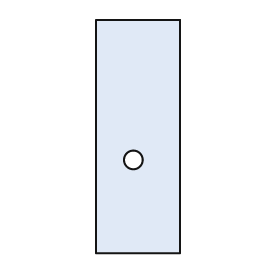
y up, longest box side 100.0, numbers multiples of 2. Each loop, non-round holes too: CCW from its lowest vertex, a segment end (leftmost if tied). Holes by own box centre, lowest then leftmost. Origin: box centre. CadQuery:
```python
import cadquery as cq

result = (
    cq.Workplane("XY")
    .moveTo(-18.0, -50.0)
    .lineTo(18.0, -50.0)
    .lineTo(18.0, 50.0)
    .lineTo(-18.0, 50.0)
    .close()
    .moveTo(-2.0, -10.0)
    .circle(4.0)
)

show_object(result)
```